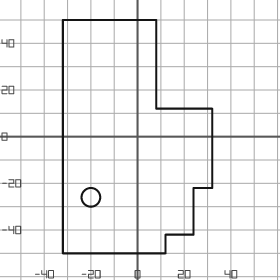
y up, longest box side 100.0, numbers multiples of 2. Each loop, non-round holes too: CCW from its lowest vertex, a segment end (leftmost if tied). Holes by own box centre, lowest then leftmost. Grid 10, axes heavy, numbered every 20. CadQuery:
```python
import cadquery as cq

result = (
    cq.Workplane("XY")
    .moveTo(-32.0, -50.0)
    .lineTo(12.0, -50.0)
    .lineTo(12.0, -42.0)
    .lineTo(24.0, -42.0)
    .lineTo(24.0, -22.0)
    .lineTo(32.0, -22.0)
    .lineTo(32.0, 12.0)
    .lineTo(8.0, 12.0)
    .lineTo(8.0, 50.0)
    .lineTo(-32.0, 50.0)
    .close()
    .moveTo(-20.0, -26.0)
    .circle(4.0)
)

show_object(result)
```